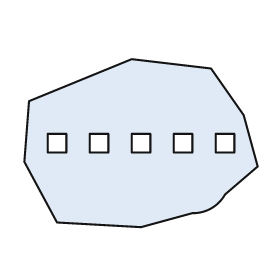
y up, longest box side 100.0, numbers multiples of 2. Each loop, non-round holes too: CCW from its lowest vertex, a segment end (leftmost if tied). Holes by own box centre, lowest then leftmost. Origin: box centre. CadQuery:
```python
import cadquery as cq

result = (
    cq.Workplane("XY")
    .moveTo(0.0, -36.0)
    .lineTo(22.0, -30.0)
    .threePointArc((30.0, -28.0), (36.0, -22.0))
    .lineTo(50.0, -10.0)
    .lineTo(44.0, 12.0)
    .lineTo(30.0, 32.0)
    .lineTo(-4.0, 36.0)
    .lineTo(-48.0, 18.0)
    .lineTo(-50.0, -8.0)
    .lineTo(-36.0, -34.0)
    .close()
    .moveTo(-40.0, -4.0)
    .lineTo(-32.0, -4.0)
    .lineTo(-32.0, 4.0)
    .lineTo(-40.0, 4.0)
    .close()
    .moveTo(-22.0, -4.0)
    .lineTo(-14.0, -4.0)
    .lineTo(-14.0, 4.0)
    .lineTo(-22.0, 4.0)
    .close()
    .moveTo(-4.0, -4.0)
    .lineTo(4.0, -4.0)
    .lineTo(4.0, 4.0)
    .lineTo(-4.0, 4.0)
    .close()
    .moveTo(14.0, -4.0)
    .lineTo(22.0, -4.0)
    .lineTo(22.0, 4.0)
    .lineTo(14.0, 4.0)
    .close()
    .moveTo(32.0, -4.0)
    .lineTo(40.0, -4.0)
    .lineTo(40.0, 4.0)
    .lineTo(32.0, 4.0)
    .close()
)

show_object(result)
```